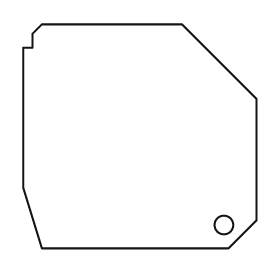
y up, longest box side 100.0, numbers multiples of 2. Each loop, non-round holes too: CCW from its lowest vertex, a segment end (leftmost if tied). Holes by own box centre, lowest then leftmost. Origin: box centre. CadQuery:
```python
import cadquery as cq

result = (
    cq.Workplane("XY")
    .moveTo(-42.0, -48.0)
    .lineTo(38.0, -48.0)
    .lineTo(50.0, -36.0)
    .lineTo(50.0, 16.0)
    .lineTo(18.0, 48.0)
    .lineTo(-42.0, 48.0)
    .lineTo(-46.0, 44.0)
    .lineTo(-46.0, 38.0)
    .lineTo(-50.0, 38.0)
    .lineTo(-50.0, -22.0)
    .close()
    .moveTo(36.0, -38.0)
    .circle(4.0)
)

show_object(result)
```